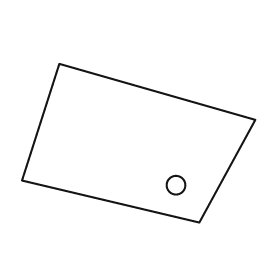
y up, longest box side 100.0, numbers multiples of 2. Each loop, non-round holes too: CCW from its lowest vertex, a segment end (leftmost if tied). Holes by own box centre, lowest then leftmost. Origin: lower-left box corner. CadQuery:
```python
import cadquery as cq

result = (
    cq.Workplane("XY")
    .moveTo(76.0, 0.0)
    .lineTo(100.0, 44.0)
    .lineTo(16.0, 68.0)
    .lineTo(0.0, 18.0)
    .close()
    .moveTo(66.0, 16.0)
    .circle(4.0)
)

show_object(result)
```